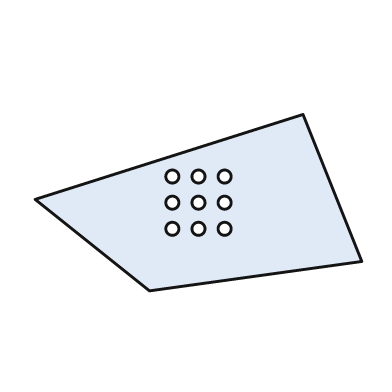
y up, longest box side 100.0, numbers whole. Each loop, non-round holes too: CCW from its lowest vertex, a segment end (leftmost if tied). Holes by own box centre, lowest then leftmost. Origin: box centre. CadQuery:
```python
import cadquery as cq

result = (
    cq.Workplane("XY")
    .moveTo(-15.0, -27.0)
    .lineTo(50.0, -18.0)
    .lineTo(32.0, 27.0)
    .lineTo(-50.0, 1.0)
    .close()
    .moveTo(-8.0, -8.0)
    .circle(2.0)
    .moveTo(0.0, -8.0)
    .circle(2.0)
    .moveTo(8.0, -8.0)
    .circle(2.0)
    .moveTo(-8.0, 0.0)
    .circle(2.0)
    .moveTo(0.0, 0.0)
    .circle(2.0)
    .moveTo(8.0, 0.0)
    .circle(2.0)
    .moveTo(-8.0, 8.0)
    .circle(2.0)
    .moveTo(0.0, 8.0)
    .circle(2.0)
    .moveTo(8.0, 8.0)
    .circle(2.0)
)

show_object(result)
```